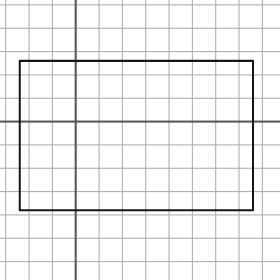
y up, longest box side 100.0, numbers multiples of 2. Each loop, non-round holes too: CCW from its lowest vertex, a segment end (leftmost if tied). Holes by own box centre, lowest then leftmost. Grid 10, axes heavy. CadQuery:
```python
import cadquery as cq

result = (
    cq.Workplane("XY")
    .moveTo(-24.0, -38.0)
    .lineTo(76.0, -38.0)
    .lineTo(76.0, 26.0)
    .lineTo(-24.0, 26.0)
    .close()
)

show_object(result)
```